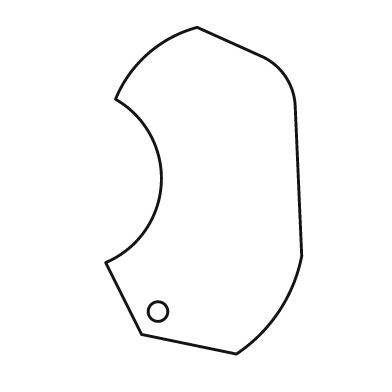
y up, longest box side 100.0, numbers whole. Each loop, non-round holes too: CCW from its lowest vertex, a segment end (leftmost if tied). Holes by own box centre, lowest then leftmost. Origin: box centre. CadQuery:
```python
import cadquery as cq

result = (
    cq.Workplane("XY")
    .moveTo(10.0, -50.0)
    .threePointArc((23.0, -37.0), (30.0, -20.0))
    .lineTo(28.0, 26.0)
    .threePointArc((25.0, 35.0), (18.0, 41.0))
    .lineTo(-2.0, 50.0)
    .threePointArc((-17.0, 42.0), (-27.0, 28.0))
    .threePointArc((-13.0, 2.0), (-30.0, -22.0))
    .lineTo(-19.0, -44.0)
    .close()
    .moveTo(-14.0, -37.0)
    .circle(3.0)
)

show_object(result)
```